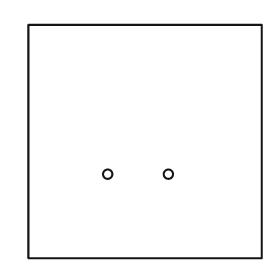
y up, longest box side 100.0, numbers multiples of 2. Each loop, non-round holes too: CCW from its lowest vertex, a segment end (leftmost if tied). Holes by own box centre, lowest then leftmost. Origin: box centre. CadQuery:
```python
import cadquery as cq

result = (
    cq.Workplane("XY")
    .moveTo(-50.0, -50.0)
    .lineTo(50.0, -50.0)
    .lineTo(50.0, 50.0)
    .lineTo(-50.0, 50.0)
    .close()
    .moveTo(-16.0, -14.0)
    .circle(2.0)
    .moveTo(10.0, -14.0)
    .circle(2.0)
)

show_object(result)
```